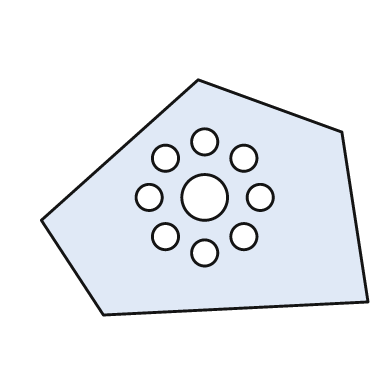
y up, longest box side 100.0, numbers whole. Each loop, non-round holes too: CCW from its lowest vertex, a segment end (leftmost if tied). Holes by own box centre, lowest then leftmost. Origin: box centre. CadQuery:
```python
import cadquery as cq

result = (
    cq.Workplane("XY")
    .moveTo(-31.0, -36.0)
    .lineTo(50.0, -32.0)
    .lineTo(42.0, 20.0)
    .lineTo(-2.0, 36.0)
    .lineTo(-50.0, -7.0)
    .close()
    .moveTo(0.0, -17.0)
    .circle(4.0)
    .moveTo(-12.0, -12.0)
    .circle(4.0)
    .moveTo(12.0, -12.0)
    .circle(4.0)
    .moveTo(-17.0, 0.0)
    .circle(4.0)
    .moveTo(0.0, 0.0)
    .circle(7.0)
    .moveTo(17.0, 0.0)
    .circle(4.0)
    .moveTo(-12.0, 12.0)
    .circle(4.0)
    .moveTo(12.0, 12.0)
    .circle(4.0)
    .moveTo(0.0, 17.0)
    .circle(4.0)
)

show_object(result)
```